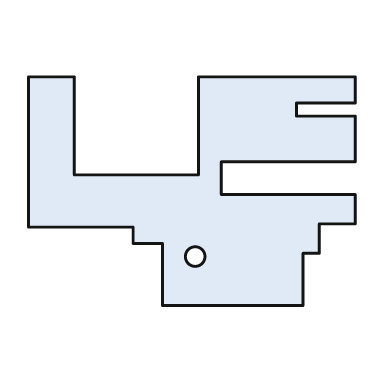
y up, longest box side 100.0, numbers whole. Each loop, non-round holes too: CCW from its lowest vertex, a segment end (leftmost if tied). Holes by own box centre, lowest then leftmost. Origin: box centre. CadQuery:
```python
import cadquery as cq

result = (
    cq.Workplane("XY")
    .moveTo(-9.0, -35.0)
    .lineTo(34.0, -35.0)
    .lineTo(34.0, -19.0)
    .lineTo(39.0, -19.0)
    .lineTo(39.0, -10.0)
    .lineTo(50.0, -10.0)
    .lineTo(50.0, -1.0)
    .lineTo(9.0, -1.0)
    .lineTo(9.0, 9.0)
    .lineTo(50.0, 9.0)
    .lineTo(50.0, 23.0)
    .lineTo(32.0, 23.0)
    .lineTo(32.0, 27.0)
    .lineTo(50.0, 27.0)
    .lineTo(50.0, 35.0)
    .lineTo(2.0, 35.0)
    .lineTo(2.0, 5.0)
    .lineTo(-36.0, 5.0)
    .lineTo(-36.0, 35.0)
    .lineTo(-50.0, 35.0)
    .lineTo(-50.0, -11.0)
    .lineTo(-18.0, -11.0)
    .lineTo(-18.0, -16.0)
    .lineTo(-9.0, -16.0)
    .close()
    .moveTo(1.0, -20.0)
    .circle(3.0)
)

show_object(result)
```